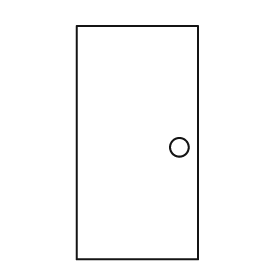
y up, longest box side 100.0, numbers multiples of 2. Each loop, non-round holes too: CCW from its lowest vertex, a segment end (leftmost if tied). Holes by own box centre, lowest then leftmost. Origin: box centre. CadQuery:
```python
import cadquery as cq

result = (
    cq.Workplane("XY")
    .moveTo(-26.0, -50.0)
    .lineTo(26.0, -50.0)
    .lineTo(26.0, 50.0)
    .lineTo(-26.0, 50.0)
    .close()
    .moveTo(18.0, -2.0)
    .circle(4.0)
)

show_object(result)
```